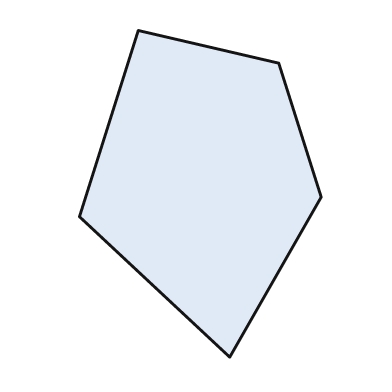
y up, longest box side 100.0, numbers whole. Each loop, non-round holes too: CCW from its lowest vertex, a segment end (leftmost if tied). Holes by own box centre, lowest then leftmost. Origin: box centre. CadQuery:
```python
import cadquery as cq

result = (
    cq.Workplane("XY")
    .moveTo(9.0, -50.0)
    .lineTo(37.0, -1.0)
    .lineTo(24.0, 40.0)
    .lineTo(-19.0, 50.0)
    .lineTo(-37.0, -7.0)
    .close()
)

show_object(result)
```